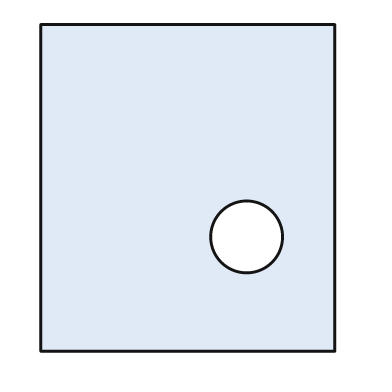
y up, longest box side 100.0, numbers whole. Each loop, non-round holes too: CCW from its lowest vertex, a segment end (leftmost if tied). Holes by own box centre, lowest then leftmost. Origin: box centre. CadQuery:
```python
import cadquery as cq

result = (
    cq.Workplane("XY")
    .moveTo(-45.0, -50.0)
    .lineTo(45.0, -50.0)
    .lineTo(45.0, 50.0)
    .lineTo(-45.0, 50.0)
    .close()
    .moveTo(18.0, -15.0)
    .circle(11.0)
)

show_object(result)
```